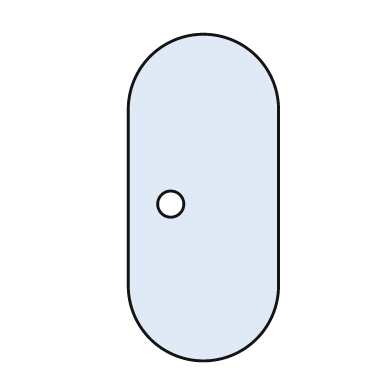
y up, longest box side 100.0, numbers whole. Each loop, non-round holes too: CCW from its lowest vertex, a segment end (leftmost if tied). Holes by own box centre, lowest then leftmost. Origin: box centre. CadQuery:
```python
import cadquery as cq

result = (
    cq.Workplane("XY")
    .moveTo(-23.0, -27.0)
    .threePointArc((0.0, -50.0), (23.0, -27.0))
    .lineTo(23.0, 27.0)
    .threePointArc((0.0, 50.0), (-23.0, 27.0))
    .close()
    .moveTo(-10.0, -2.0)
    .circle(4.0)
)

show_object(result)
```